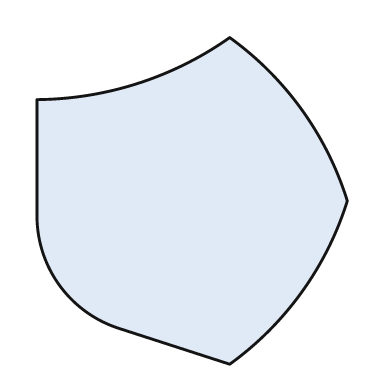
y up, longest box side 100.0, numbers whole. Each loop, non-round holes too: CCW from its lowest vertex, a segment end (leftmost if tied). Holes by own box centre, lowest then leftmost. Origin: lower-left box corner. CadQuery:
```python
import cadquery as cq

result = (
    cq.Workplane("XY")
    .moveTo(59.0, 0.0)
    .threePointArc((81.0, 22.0), (95.0, 50.0))
    .threePointArc((81.0, 78.0), (59.0, 100.0))
    .threePointArc((31.0, 86.0), (0.0, 81.0))
    .lineTo(0.0, 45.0)
    .threePointArc((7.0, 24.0), (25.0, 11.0))
    .close()
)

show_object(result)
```